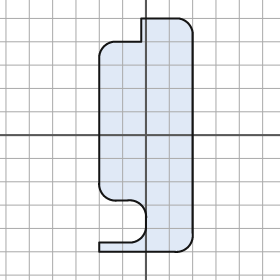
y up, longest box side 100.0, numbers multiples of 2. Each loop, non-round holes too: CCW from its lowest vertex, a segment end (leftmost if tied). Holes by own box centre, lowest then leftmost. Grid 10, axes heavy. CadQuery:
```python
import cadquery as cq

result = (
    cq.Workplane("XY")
    .moveTo(-20.0, -50.0)
    .lineTo(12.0, -50.0)
    .threePointArc((18.0, -48.0), (20.0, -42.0))
    .lineTo(20.0, 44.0)
    .threePointArc((18.0, 48.0), (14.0, 50.0))
    .lineTo(-2.0, 50.0)
    .lineTo(-2.0, 40.0)
    .lineTo(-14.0, 40.0)
    .threePointArc((-18.0, 38.0), (-20.0, 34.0))
    .lineTo(-20.0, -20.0)
    .threePointArc((-18.0, -26.0), (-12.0, -28.0))
    .lineTo(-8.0, -28.0)
    .threePointArc((-2.0, -30.0), (0.0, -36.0))
    .lineTo(0.0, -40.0)
    .threePointArc((-2.0, -44.0), (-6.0, -46.0))
    .lineTo(-20.0, -46.0)
    .close()
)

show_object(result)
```